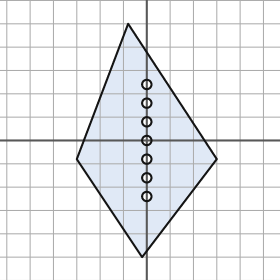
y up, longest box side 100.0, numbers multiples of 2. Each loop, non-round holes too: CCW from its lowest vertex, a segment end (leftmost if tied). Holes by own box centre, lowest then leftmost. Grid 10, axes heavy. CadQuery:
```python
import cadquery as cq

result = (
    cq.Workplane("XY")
    .moveTo(-2.0, -50.0)
    .lineTo(30.0, -8.0)
    .lineTo(-8.0, 50.0)
    .lineTo(-30.0, -8.0)
    .close()
    .moveTo(0.0, -24.0)
    .circle(2.0)
    .moveTo(0.0, -16.0)
    .circle(2.0)
    .moveTo(0.0, -8.0)
    .circle(2.0)
    .moveTo(0.0, 0.0)
    .circle(2.0)
    .moveTo(0.0, 8.0)
    .circle(2.0)
    .moveTo(0.0, 16.0)
    .circle(2.0)
    .moveTo(0.0, 24.0)
    .circle(2.0)
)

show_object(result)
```